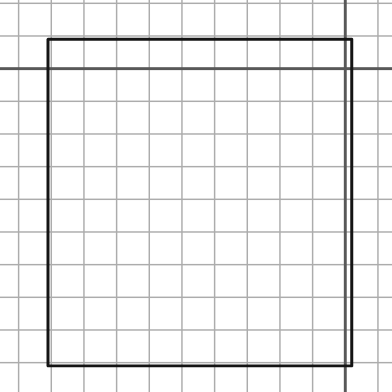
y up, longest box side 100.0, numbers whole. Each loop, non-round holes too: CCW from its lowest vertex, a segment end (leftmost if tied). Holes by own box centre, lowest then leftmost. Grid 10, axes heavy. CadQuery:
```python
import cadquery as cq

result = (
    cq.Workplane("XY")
    .moveTo(-91.0, -91.0)
    .lineTo(2.0, -91.0)
    .lineTo(2.0, 9.0)
    .lineTo(-91.0, 9.0)
    .close()
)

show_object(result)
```